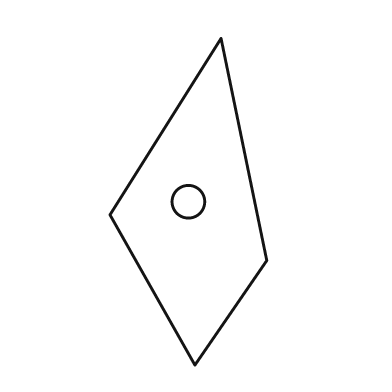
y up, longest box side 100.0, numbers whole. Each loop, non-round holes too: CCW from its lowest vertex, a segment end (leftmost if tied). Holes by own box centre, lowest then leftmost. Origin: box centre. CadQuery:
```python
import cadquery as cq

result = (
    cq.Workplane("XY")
    .moveTo(2.0, -50.0)
    .lineTo(24.0, -18.0)
    .lineTo(10.0, 50.0)
    .lineTo(-24.0, -4.0)
    .close()
    .moveTo(0.0, 0.0)
    .circle(5.0)
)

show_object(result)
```